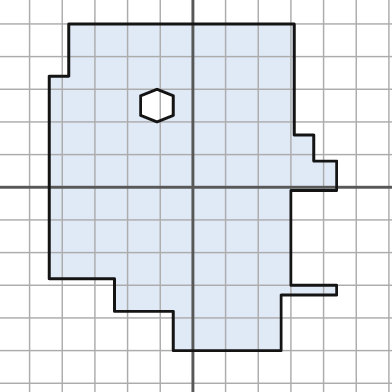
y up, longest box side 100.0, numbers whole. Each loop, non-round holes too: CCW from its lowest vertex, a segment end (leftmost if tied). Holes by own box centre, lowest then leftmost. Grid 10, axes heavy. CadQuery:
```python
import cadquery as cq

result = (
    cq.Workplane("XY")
    .moveTo(-6.0, -50.0)
    .lineTo(27.0, -50.0)
    .lineTo(27.0, -33.0)
    .lineTo(44.0, -33.0)
    .lineTo(44.0, -30.0)
    .lineTo(30.0, -30.0)
    .lineTo(30.0, -1.0)
    .lineTo(44.0, -1.0)
    .lineTo(44.0, 8.0)
    .lineTo(37.0, 8.0)
    .lineTo(37.0, 16.0)
    .lineTo(31.0, 16.0)
    .lineTo(31.0, 50.0)
    .lineTo(-38.0, 50.0)
    .lineTo(-38.0, 34.0)
    .lineTo(-44.0, 34.0)
    .lineTo(-44.0, -28.0)
    .lineTo(-24.0, -28.0)
    .lineTo(-24.0, -38.0)
    .lineTo(-6.0, -38.0)
    .close()
    .moveTo(-11.0, 20.0)
    .lineTo(-6.0, 22.0)
    .lineTo(-6.0, 28.0)
    .lineTo(-11.0, 30.0)
    .lineTo(-16.0, 28.0)
    .lineTo(-16.0, 22.0)
    .close()
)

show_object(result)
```